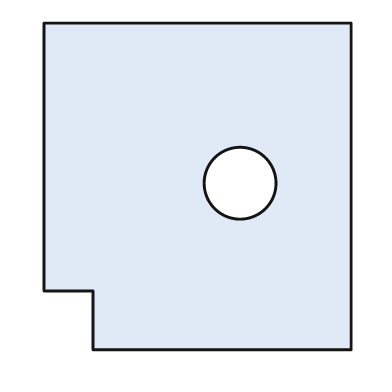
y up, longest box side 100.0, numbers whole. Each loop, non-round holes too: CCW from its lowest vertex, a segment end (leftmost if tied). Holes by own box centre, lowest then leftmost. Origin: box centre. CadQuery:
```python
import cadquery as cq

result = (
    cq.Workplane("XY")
    .moveTo(-32.0, -50.0)
    .lineTo(47.0, -50.0)
    .lineTo(47.0, 50.0)
    .lineTo(-47.0, 50.0)
    .lineTo(-47.0, -32.0)
    .lineTo(-32.0, -32.0)
    .close()
    .moveTo(13.0, 1.0)
    .circle(11.0)
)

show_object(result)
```